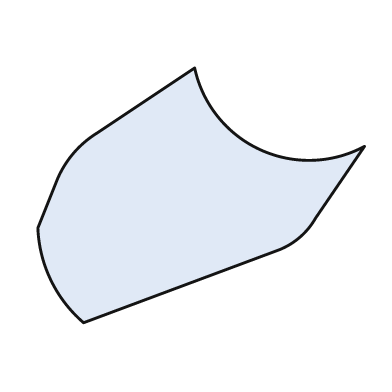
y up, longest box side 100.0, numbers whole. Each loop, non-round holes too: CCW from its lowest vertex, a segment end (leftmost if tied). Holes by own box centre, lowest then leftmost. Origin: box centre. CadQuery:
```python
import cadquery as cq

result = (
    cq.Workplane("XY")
    .moveTo(-36.0, -39.0)
    .lineTo(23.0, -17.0)
    .threePointArc((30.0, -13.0), (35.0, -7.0))
    .lineTo(50.0, 15.0)
    .threePointArc((18.0, 14.0), (-2.0, 39.0))
    .lineTo(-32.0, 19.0)
    .threePointArc((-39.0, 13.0), (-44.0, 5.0))
    .lineTo(-50.0, -10.0)
    .threePointArc((-46.0, -26.0), (-36.0, -39.0))
    .close()
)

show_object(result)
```